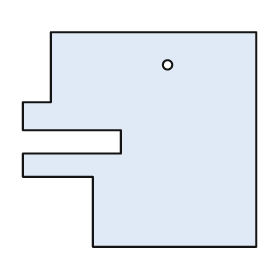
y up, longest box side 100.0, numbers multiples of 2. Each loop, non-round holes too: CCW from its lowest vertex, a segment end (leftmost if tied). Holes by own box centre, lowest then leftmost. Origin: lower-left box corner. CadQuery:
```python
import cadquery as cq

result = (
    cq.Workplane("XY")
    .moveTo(30.0, 0.0)
    .lineTo(100.0, 0.0)
    .lineTo(100.0, 92.0)
    .lineTo(12.0, 92.0)
    .lineTo(12.0, 62.0)
    .lineTo(0.0, 62.0)
    .lineTo(0.0, 50.0)
    .lineTo(42.0, 50.0)
    .lineTo(42.0, 40.0)
    .lineTo(0.0, 40.0)
    .lineTo(0.0, 30.0)
    .lineTo(30.0, 30.0)
    .close()
    .moveTo(62.0, 78.0)
    .circle(2.0)
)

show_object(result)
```